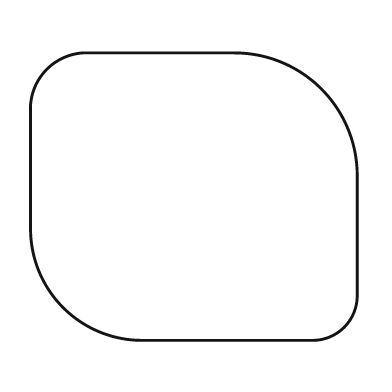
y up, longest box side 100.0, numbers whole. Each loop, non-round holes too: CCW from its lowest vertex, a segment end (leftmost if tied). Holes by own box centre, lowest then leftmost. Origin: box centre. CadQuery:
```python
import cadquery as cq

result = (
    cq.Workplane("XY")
    .moveTo(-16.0, -44.0)
    .lineTo(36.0, -44.0)
    .threePointArc((46.0, -40.0), (50.0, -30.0))
    .lineTo(50.0, 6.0)
    .threePointArc((39.0, 33.0), (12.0, 44.0))
    .lineTo(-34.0, 44.0)
    .threePointArc((-45.0, 39.0), (-50.0, 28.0))
    .lineTo(-50.0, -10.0)
    .threePointArc((-40.0, -34.0), (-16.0, -44.0))
    .close()
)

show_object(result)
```